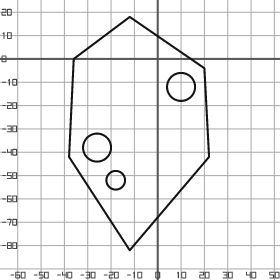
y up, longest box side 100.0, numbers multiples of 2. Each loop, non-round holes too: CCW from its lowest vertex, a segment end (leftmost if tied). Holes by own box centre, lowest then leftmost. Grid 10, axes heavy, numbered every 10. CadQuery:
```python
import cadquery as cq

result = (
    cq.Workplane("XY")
    .moveTo(-12.0, -82.0)
    .lineTo(22.0, -42.0)
    .lineTo(20.0, -4.0)
    .lineTo(-12.0, 18.0)
    .lineTo(-36.0, 0.0)
    .lineTo(-38.0, -42.0)
    .close()
    .moveTo(-18.0, -52.0)
    .circle(4.0)
    .moveTo(-26.0, -38.0)
    .circle(6.0)
    .moveTo(10.0, -12.0)
    .circle(6.0)
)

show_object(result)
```